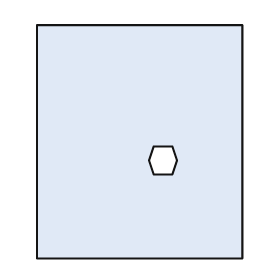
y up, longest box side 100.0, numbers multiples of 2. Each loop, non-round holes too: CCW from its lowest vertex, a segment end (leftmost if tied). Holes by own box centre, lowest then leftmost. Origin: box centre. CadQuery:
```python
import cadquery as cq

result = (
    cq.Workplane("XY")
    .moveTo(-44.0, -50.0)
    .lineTo(44.0, -50.0)
    .lineTo(44.0, 50.0)
    .lineTo(-44.0, 50.0)
    .close()
    .moveTo(6.0, -14.0)
    .lineTo(14.0, -14.0)
    .lineTo(16.0, -8.0)
    .lineTo(14.0, -2.0)
    .lineTo(6.0, -2.0)
    .lineTo(4.0, -8.0)
    .close()
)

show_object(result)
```